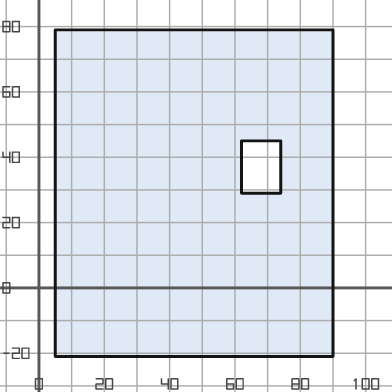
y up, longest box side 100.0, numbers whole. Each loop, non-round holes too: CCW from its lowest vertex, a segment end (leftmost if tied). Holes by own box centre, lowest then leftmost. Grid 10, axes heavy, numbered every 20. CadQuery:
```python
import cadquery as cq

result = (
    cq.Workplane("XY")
    .moveTo(5.0, -21.0)
    .lineTo(90.0, -21.0)
    .lineTo(90.0, 79.0)
    .lineTo(5.0, 79.0)
    .close()
    .moveTo(62.0, 29.0)
    .lineTo(74.0, 29.0)
    .lineTo(74.0, 45.0)
    .lineTo(62.0, 45.0)
    .close()
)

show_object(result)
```